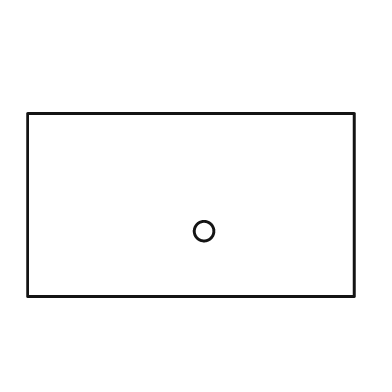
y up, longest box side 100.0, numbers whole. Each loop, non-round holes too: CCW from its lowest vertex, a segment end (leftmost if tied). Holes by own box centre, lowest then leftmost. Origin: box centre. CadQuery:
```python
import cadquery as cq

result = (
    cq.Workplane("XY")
    .moveTo(-50.0, -28.0)
    .lineTo(50.0, -28.0)
    .lineTo(50.0, 28.0)
    .lineTo(-50.0, 28.0)
    .close()
    .moveTo(4.0, -8.0)
    .circle(3.0)
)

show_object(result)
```